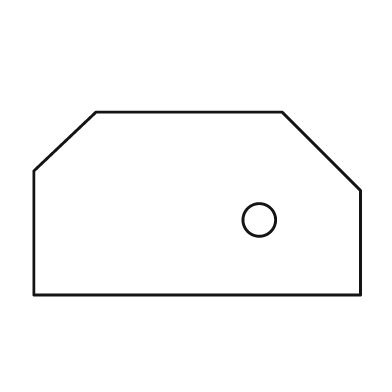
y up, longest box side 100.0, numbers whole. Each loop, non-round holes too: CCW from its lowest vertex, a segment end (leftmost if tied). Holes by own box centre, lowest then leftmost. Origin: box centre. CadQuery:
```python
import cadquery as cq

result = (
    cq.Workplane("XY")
    .moveTo(-50.0, -28.0)
    .lineTo(50.0, -28.0)
    .lineTo(50.0, 4.0)
    .lineTo(26.0, 28.0)
    .lineTo(-31.0, 28.0)
    .lineTo(-50.0, 10.0)
    .close()
    .moveTo(19.0, -5.0)
    .circle(5.0)
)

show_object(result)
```